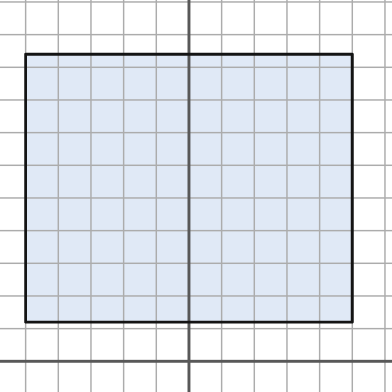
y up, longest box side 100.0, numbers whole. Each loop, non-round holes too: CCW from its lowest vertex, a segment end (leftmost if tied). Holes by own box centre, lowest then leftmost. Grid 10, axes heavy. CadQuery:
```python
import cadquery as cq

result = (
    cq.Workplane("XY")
    .moveTo(-50.0, 12.0)
    .lineTo(50.0, 12.0)
    .lineTo(50.0, 94.0)
    .lineTo(-50.0, 94.0)
    .close()
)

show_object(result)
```